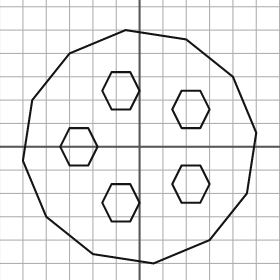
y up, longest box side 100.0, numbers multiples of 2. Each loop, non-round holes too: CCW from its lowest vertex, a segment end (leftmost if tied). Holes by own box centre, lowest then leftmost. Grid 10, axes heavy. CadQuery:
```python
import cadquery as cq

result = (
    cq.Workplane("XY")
    .moveTo(6.0, -50.0)
    .lineTo(30.0, -40.0)
    .lineTo(46.0, -20.0)
    .lineTo(50.0, 6.0)
    .lineTo(40.0, 30.0)
    .lineTo(20.0, 46.0)
    .lineTo(-6.0, 50.0)
    .lineTo(-30.0, 40.0)
    .lineTo(-46.0, 20.0)
    .lineTo(-50.0, -6.0)
    .lineTo(-40.0, -30.0)
    .lineTo(-20.0, -46.0)
    .close()
    .moveTo(-12.0, -32.0)
    .lineTo(-4.0, -32.0)
    .lineTo(0.0, -24.0)
    .lineTo(-4.0, -16.0)
    .lineTo(-12.0, -16.0)
    .lineTo(-16.0, -24.0)
    .close()
    .moveTo(18.0, -24.0)
    .lineTo(26.0, -24.0)
    .lineTo(30.0, -16.0)
    .lineTo(26.0, -8.0)
    .lineTo(18.0, -8.0)
    .lineTo(14.0, -16.0)
    .close()
    .moveTo(-30.0, -8.0)
    .lineTo(-22.0, -8.0)
    .lineTo(-18.0, 0.0)
    .lineTo(-22.0, 8.0)
    .lineTo(-30.0, 8.0)
    .lineTo(-34.0, 0.0)
    .close()
    .moveTo(18.0, 8.0)
    .lineTo(26.0, 8.0)
    .lineTo(30.0, 16.0)
    .lineTo(26.0, 24.0)
    .lineTo(18.0, 24.0)
    .lineTo(14.0, 16.0)
    .close()
    .moveTo(-12.0, 16.0)
    .lineTo(-4.0, 16.0)
    .lineTo(0.0, 24.0)
    .lineTo(-4.0, 32.0)
    .lineTo(-12.0, 32.0)
    .lineTo(-16.0, 24.0)
    .close()
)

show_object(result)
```